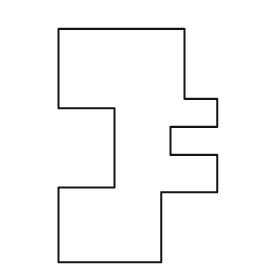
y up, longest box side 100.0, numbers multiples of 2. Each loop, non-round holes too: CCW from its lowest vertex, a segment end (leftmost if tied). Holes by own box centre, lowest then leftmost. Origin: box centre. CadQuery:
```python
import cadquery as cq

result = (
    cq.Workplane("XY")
    .moveTo(-34.0, -50.0)
    .lineTo(10.0, -50.0)
    .lineTo(10.0, -20.0)
    .lineTo(34.0, -20.0)
    .lineTo(34.0, -4.0)
    .lineTo(14.0, -4.0)
    .lineTo(14.0, 8.0)
    .lineTo(34.0, 8.0)
    .lineTo(34.0, 20.0)
    .lineTo(20.0, 20.0)
    .lineTo(20.0, 50.0)
    .lineTo(-34.0, 50.0)
    .lineTo(-34.0, 16.0)
    .lineTo(-10.0, 16.0)
    .lineTo(-10.0, -18.0)
    .lineTo(-34.0, -18.0)
    .close()
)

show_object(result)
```